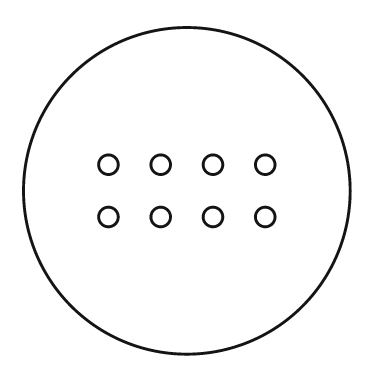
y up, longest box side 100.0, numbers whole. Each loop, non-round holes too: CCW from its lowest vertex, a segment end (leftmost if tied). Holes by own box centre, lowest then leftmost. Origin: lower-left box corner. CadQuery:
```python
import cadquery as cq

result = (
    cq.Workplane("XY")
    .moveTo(50.0, 50.0)
    .circle(50.0)
    .moveTo(26.0, 42.0)
    .circle(3.0)
    .moveTo(42.0, 42.0)
    .circle(3.0)
    .moveTo(58.0, 42.0)
    .circle(3.0)
    .moveTo(74.0, 42.0)
    .circle(3.0)
    .moveTo(26.0, 58.0)
    .circle(3.0)
    .moveTo(42.0, 58.0)
    .circle(3.0)
    .moveTo(58.0, 58.0)
    .circle(3.0)
    .moveTo(74.0, 58.0)
    .circle(3.0)
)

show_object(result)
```